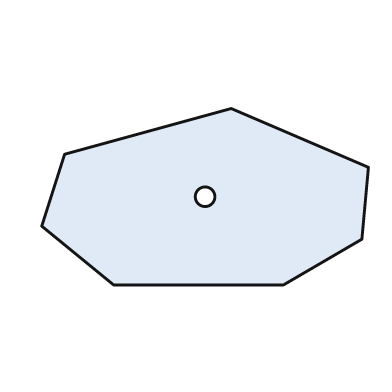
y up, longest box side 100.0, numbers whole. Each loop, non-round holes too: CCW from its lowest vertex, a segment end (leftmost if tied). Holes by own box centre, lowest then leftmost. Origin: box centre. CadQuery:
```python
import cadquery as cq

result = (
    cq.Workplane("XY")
    .moveTo(-28.0, -27.0)
    .lineTo(24.0, -27.0)
    .lineTo(48.0, -13.0)
    .lineTo(50.0, 9.0)
    .lineTo(8.0, 27.0)
    .lineTo(-43.0, 13.0)
    .lineTo(-50.0, -9.0)
    .close()
    .moveTo(0.0, 0.0)
    .circle(3.0)
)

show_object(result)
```